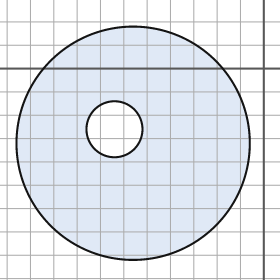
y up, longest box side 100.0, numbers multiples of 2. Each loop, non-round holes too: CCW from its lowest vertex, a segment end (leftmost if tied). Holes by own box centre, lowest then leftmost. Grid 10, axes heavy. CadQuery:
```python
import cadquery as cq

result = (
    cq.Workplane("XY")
    .moveTo(-56.0, -32.0)
    .circle(50.0)
    .moveTo(-64.0, -26.0)
    .circle(12.0)
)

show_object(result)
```